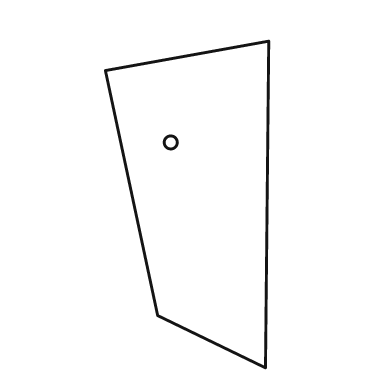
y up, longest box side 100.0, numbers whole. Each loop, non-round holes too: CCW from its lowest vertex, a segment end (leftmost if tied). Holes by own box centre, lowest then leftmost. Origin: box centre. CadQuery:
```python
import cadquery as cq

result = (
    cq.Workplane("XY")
    .moveTo(24.0, -50.0)
    .lineTo(25.0, 50.0)
    .lineTo(-25.0, 41.0)
    .lineTo(-9.0, -34.0)
    .close()
    .moveTo(-5.0, 19.0)
    .circle(2.0)
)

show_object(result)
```